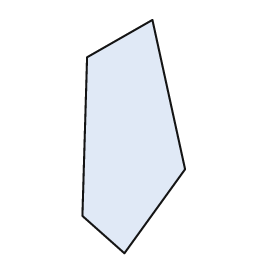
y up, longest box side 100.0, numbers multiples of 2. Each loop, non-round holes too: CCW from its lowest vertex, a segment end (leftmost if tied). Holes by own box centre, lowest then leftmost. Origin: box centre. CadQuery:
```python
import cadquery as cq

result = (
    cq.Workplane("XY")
    .moveTo(-4.0, -50.0)
    .lineTo(22.0, -14.0)
    .lineTo(8.0, 50.0)
    .lineTo(-20.0, 34.0)
    .lineTo(-22.0, -34.0)
    .close()
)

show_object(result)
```